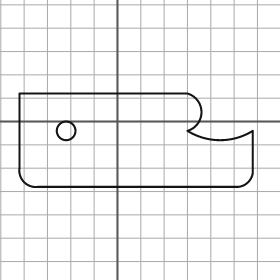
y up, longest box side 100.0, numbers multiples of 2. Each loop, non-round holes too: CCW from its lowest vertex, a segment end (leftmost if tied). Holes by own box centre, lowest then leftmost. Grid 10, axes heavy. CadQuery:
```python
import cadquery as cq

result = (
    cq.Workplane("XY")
    .moveTo(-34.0, -28.0)
    .lineTo(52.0, -28.0)
    .threePointArc((56.0, -26.0), (58.0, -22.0))
    .lineTo(58.0, -4.0)
    .threePointArc((44.0, -8.0), (30.0, -4.0))
    .threePointArc((36.0, 4.0), (30.0, 12.0))
    .lineTo(-42.0, 12.0)
    .lineTo(-42.0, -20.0)
    .threePointArc((-40.0, -26.0), (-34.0, -28.0))
    .close()
    .moveTo(-22.0, -4.0)
    .circle(4.0)
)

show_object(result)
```